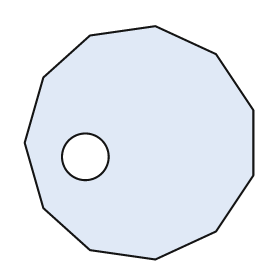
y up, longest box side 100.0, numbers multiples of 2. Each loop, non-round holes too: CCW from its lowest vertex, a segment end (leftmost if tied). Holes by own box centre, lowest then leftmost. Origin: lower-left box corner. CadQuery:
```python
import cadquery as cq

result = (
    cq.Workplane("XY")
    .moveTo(56.0, 0.0)
    .lineTo(82.0, 12.0)
    .lineTo(98.0, 36.0)
    .lineTo(98.0, 64.0)
    .lineTo(82.0, 88.0)
    .lineTo(56.0, 100.0)
    .lineTo(28.0, 96.0)
    .lineTo(8.0, 78.0)
    .lineTo(0.0, 50.0)
    .lineTo(8.0, 22.0)
    .lineTo(28.0, 4.0)
    .close()
    .moveTo(26.0, 44.0)
    .circle(10.0)
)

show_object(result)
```